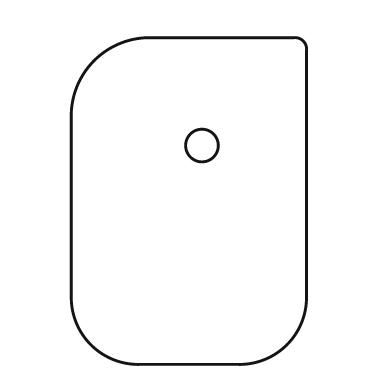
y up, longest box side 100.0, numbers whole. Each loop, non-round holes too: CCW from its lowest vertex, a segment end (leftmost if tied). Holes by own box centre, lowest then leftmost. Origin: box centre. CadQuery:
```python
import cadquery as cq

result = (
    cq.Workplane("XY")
    .moveTo(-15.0, -50.0)
    .lineTo(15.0, -50.0)
    .threePointArc((30.0, -44.0), (36.0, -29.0))
    .lineTo(36.0, 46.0)
    .threePointArc((35.0, 49.0), (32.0, 50.0))
    .lineTo(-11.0, 50.0)
    .threePointArc((-29.0, 43.0), (-36.0, 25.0))
    .lineTo(-36.0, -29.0)
    .threePointArc((-30.0, -44.0), (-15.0, -50.0))
    .close()
    .moveTo(4.0, 17.0)
    .circle(5.0)
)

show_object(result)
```